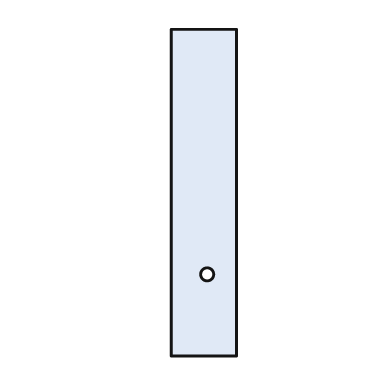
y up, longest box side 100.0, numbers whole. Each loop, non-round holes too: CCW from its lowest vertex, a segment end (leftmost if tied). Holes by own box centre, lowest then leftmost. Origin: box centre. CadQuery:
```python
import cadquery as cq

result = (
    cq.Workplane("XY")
    .moveTo(-10.0, -50.0)
    .lineTo(10.0, -50.0)
    .lineTo(10.0, 50.0)
    .lineTo(-10.0, 50.0)
    .close()
    .moveTo(1.0, -25.0)
    .circle(2.0)
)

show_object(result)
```